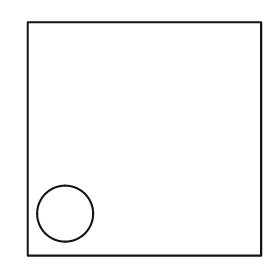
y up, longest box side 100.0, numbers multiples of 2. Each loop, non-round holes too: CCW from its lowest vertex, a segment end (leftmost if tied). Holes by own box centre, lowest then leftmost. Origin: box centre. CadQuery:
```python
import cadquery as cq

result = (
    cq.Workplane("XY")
    .moveTo(-50.0, -50.0)
    .lineTo(50.0, -50.0)
    .lineTo(50.0, 50.0)
    .lineTo(-50.0, 50.0)
    .close()
    .moveTo(-34.0, -32.0)
    .circle(12.0)
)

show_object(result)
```